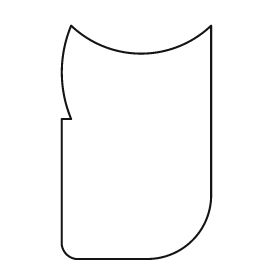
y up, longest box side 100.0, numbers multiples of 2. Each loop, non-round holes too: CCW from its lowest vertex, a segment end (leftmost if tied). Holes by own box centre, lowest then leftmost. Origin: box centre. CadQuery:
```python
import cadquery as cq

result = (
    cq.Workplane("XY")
    .moveTo(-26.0, -50.0)
    .lineTo(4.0, -50.0)
    .threePointArc((24.0, -42.0), (32.0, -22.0))
    .lineTo(32.0, 50.0)
    .threePointArc((2.0, 38.0), (-28.0, 50.0))
    .threePointArc((-32.0, 30.0), (-28.0, 10.0))
    .lineTo(-32.0, 10.0)
    .lineTo(-32.0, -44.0)
    .threePointArc((-30.0, -48.0), (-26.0, -50.0))
    .close()
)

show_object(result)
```